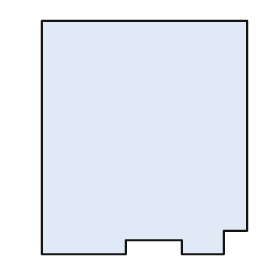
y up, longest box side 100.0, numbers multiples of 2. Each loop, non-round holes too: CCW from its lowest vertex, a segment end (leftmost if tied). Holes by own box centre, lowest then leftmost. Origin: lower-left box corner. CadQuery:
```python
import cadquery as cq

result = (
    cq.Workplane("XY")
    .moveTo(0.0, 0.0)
    .lineTo(36.0, 0.0)
    .lineTo(36.0, 6.0)
    .lineTo(60.0, 6.0)
    .lineTo(60.0, 0.0)
    .lineTo(78.0, 0.0)
    .lineTo(78.0, 10.0)
    .lineTo(88.0, 10.0)
    .lineTo(88.0, 100.0)
    .lineTo(0.0, 100.0)
    .close()
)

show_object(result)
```